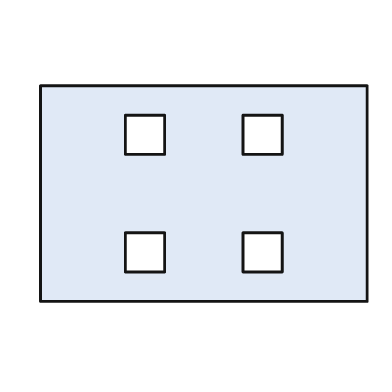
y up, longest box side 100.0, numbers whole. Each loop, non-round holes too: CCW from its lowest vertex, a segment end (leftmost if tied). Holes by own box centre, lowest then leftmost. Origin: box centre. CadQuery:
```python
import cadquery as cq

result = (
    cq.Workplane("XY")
    .moveTo(-50.0, -33.0)
    .lineTo(50.0, -33.0)
    .lineTo(50.0, 33.0)
    .lineTo(-50.0, 33.0)
    .close()
    .moveTo(-24.0, -24.0)
    .lineTo(-12.0, -24.0)
    .lineTo(-12.0, -12.0)
    .lineTo(-24.0, -12.0)
    .close()
    .moveTo(12.0, -24.0)
    .lineTo(24.0, -24.0)
    .lineTo(24.0, -12.0)
    .lineTo(12.0, -12.0)
    .close()
    .moveTo(-24.0, 12.0)
    .lineTo(-12.0, 12.0)
    .lineTo(-12.0, 24.0)
    .lineTo(-24.0, 24.0)
    .close()
    .moveTo(12.0, 12.0)
    .lineTo(24.0, 12.0)
    .lineTo(24.0, 24.0)
    .lineTo(12.0, 24.0)
    .close()
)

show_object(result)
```